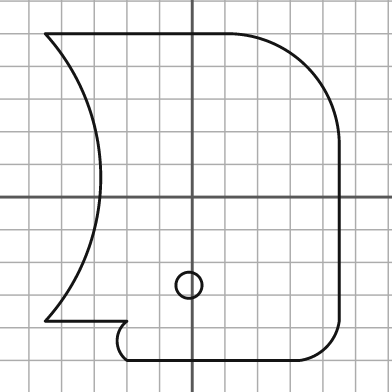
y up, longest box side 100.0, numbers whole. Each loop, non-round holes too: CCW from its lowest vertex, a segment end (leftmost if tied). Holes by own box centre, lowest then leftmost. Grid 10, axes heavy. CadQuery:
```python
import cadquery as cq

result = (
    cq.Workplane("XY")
    .moveTo(-20.0, -50.0)
    .lineTo(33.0, -50.0)
    .threePointArc((41.0, -46.0), (45.0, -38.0))
    .lineTo(45.0, 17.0)
    .threePointArc((35.0, 40.0), (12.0, 50.0))
    .lineTo(-45.0, 50.0)
    .threePointArc((-28.0, 6.0), (-45.0, -38.0))
    .lineTo(-20.0, -38.0)
    .threePointArc((-23.0, -44.0), (-20.0, -50.0))
    .close()
    .moveTo(-1.0, -27.0)
    .circle(4.0)
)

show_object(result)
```